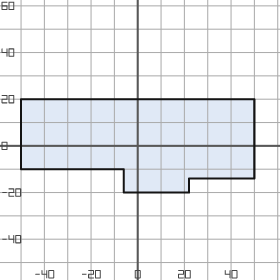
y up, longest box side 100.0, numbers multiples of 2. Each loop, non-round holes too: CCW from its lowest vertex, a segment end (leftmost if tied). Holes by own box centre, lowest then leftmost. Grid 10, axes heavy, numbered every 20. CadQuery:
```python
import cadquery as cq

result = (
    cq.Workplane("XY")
    .moveTo(-6.0, -20.0)
    .lineTo(22.0, -20.0)
    .lineTo(22.0, -14.0)
    .lineTo(50.0, -14.0)
    .lineTo(50.0, 20.0)
    .lineTo(-50.0, 20.0)
    .lineTo(-50.0, -10.0)
    .lineTo(-6.0, -10.0)
    .close()
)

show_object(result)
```